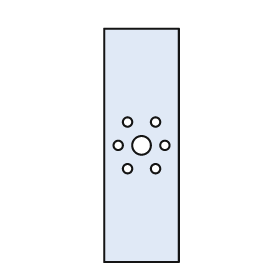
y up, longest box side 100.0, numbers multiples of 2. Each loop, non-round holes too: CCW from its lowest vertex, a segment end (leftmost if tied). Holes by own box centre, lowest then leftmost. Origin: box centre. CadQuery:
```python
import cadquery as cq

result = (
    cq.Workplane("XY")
    .moveTo(-16.0, -50.0)
    .lineTo(16.0, -50.0)
    .lineTo(16.0, 50.0)
    .lineTo(-16.0, 50.0)
    .close()
    .moveTo(-6.0, -10.0)
    .circle(2.0)
    .moveTo(6.0, -10.0)
    .circle(2.0)
    .moveTo(-10.0, 0.0)
    .circle(2.0)
    .moveTo(0.0, 0.0)
    .circle(4.0)
    .moveTo(10.0, 0.0)
    .circle(2.0)
    .moveTo(-6.0, 10.0)
    .circle(2.0)
    .moveTo(6.0, 10.0)
    .circle(2.0)
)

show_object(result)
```